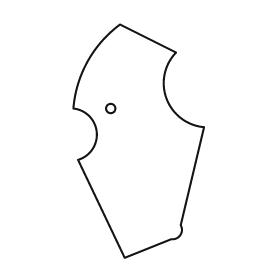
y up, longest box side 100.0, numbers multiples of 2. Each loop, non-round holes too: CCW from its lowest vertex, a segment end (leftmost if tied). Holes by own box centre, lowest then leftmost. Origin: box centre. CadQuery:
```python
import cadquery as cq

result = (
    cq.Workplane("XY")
    .moveTo(-6.0, -50.0)
    .lineTo(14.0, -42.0)
    .threePointArc((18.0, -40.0), (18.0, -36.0))
    .lineTo(28.0, 6.0)
    .threePointArc((12.0, 18.0), (16.0, 38.0))
    .lineTo(-8.0, 50.0)
    .threePointArc((-22.0, 34.0), (-28.0, 14.0))
    .threePointArc((-18.0, 4.0), (-26.0, -8.0))
    .close()
    .moveTo(-12.0, 14.0)
    .circle(2.0)
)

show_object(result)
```